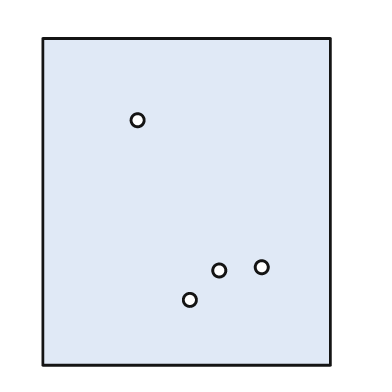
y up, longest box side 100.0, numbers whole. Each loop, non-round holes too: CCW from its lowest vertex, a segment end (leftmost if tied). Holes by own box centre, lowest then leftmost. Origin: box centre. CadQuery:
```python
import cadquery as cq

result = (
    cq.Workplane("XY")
    .moveTo(-44.0, -50.0)
    .lineTo(44.0, -50.0)
    .lineTo(44.0, 50.0)
    .lineTo(-44.0, 50.0)
    .close()
    .moveTo(1.0, -30.0)
    .circle(2.0)
    .moveTo(10.0, -21.0)
    .circle(2.0)
    .moveTo(23.0, -20.0)
    .circle(2.0)
    .moveTo(-15.0, 25.0)
    .circle(2.0)
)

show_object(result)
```